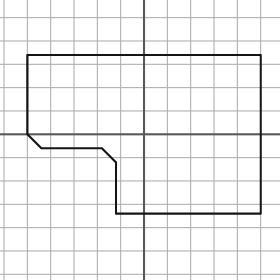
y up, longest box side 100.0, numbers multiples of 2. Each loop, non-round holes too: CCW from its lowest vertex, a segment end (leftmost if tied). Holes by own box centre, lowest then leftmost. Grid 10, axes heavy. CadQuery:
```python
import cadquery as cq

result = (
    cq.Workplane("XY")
    .moveTo(-12.0, -34.0)
    .lineTo(50.0, -34.0)
    .lineTo(50.0, 34.0)
    .lineTo(-50.0, 34.0)
    .lineTo(-50.0, 0.0)
    .lineTo(-44.0, -6.0)
    .lineTo(-18.0, -6.0)
    .lineTo(-12.0, -12.0)
    .close()
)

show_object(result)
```